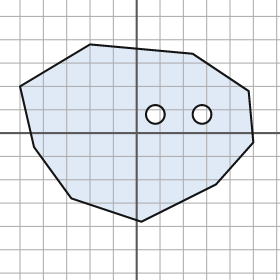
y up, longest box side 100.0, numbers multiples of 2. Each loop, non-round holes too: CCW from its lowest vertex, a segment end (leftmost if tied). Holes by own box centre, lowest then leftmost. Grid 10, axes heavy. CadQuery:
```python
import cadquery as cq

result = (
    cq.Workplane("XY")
    .moveTo(2.0, -38.0)
    .lineTo(34.0, -22.0)
    .lineTo(50.0, -4.0)
    .lineTo(48.0, 18.0)
    .lineTo(24.0, 34.0)
    .lineTo(-20.0, 38.0)
    .lineTo(-50.0, 20.0)
    .lineTo(-44.0, -6.0)
    .lineTo(-28.0, -28.0)
    .close()
    .moveTo(8.0, 8.0)
    .circle(4.0)
    .moveTo(28.0, 8.0)
    .circle(4.0)
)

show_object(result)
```